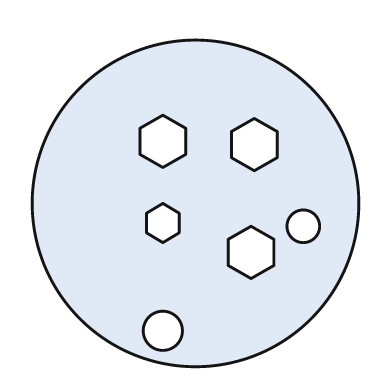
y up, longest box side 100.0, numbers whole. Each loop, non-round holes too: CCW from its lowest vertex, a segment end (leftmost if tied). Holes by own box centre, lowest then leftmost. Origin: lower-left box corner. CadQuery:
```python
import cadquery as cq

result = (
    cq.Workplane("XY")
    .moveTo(50.0, 50.0)
    .circle(50.0)
    .moveTo(40.0, 11.0)
    .circle(6.0)
    .moveTo(67.0, 27.0)
    .lineTo(74.0, 31.0)
    .lineTo(74.0, 39.0)
    .lineTo(67.0, 43.0)
    .lineTo(60.0, 39.0)
    .lineTo(60.0, 31.0)
    .close()
    .moveTo(83.0, 43.0)
    .circle(5.0)
    .moveTo(40.0, 38.0)
    .lineTo(45.0, 41.0)
    .lineTo(45.0, 47.0)
    .lineTo(40.0, 50.0)
    .lineTo(35.0, 47.0)
    .lineTo(35.0, 41.0)
    .close()
    .moveTo(68.0, 60.0)
    .lineTo(75.0, 64.0)
    .lineTo(75.0, 72.0)
    .lineTo(68.0, 76.0)
    .lineTo(61.0, 72.0)
    .lineTo(61.0, 64.0)
    .close()
    .moveTo(40.0, 61.0)
    .lineTo(47.0, 65.0)
    .lineTo(47.0, 73.0)
    .lineTo(40.0, 77.0)
    .lineTo(33.0, 73.0)
    .lineTo(33.0, 65.0)
    .close()
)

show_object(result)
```